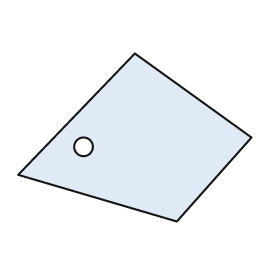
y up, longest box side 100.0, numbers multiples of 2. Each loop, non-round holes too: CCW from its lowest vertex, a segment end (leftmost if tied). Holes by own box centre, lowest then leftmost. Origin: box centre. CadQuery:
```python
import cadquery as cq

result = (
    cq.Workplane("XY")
    .moveTo(18.0, -36.0)
    .lineTo(50.0, 0.0)
    .lineTo(0.0, 36.0)
    .lineTo(-50.0, -16.0)
    .close()
    .moveTo(-22.0, -4.0)
    .circle(4.0)
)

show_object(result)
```